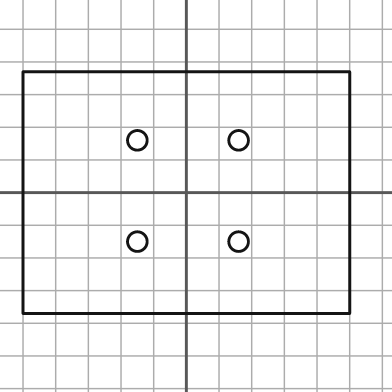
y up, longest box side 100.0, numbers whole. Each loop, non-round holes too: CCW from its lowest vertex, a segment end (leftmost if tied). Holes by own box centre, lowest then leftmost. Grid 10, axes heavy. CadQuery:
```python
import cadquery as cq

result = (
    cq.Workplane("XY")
    .moveTo(-50.0, -37.0)
    .lineTo(50.0, -37.0)
    .lineTo(50.0, 37.0)
    .lineTo(-50.0, 37.0)
    .close()
    .moveTo(-15.0, -15.0)
    .circle(3.0)
    .moveTo(16.0, -15.0)
    .circle(3.0)
    .moveTo(-15.0, 16.0)
    .circle(3.0)
    .moveTo(16.0, 16.0)
    .circle(3.0)
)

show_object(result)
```